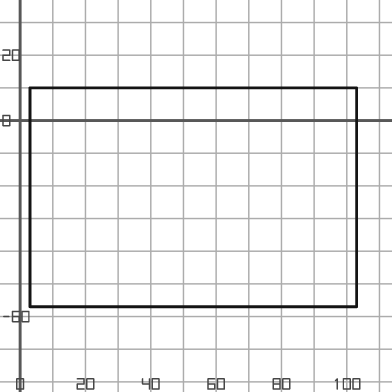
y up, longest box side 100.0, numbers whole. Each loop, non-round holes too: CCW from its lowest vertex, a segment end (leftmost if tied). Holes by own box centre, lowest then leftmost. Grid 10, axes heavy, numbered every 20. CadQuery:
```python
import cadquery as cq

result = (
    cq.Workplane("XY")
    .moveTo(3.0, -57.0)
    .lineTo(103.0, -57.0)
    .lineTo(103.0, 10.0)
    .lineTo(3.0, 10.0)
    .close()
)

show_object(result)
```